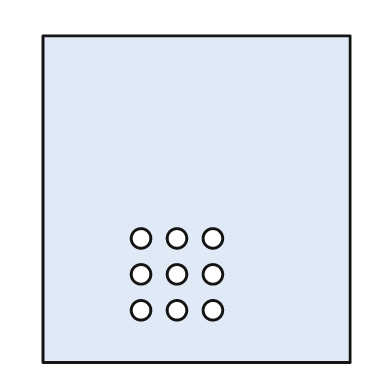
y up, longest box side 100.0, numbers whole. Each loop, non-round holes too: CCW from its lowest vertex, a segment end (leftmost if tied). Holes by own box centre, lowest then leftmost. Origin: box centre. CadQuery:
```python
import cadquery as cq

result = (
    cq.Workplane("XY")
    .moveTo(-47.0, -50.0)
    .lineTo(47.0, -50.0)
    .lineTo(47.0, 50.0)
    .lineTo(-47.0, 50.0)
    .close()
    .moveTo(-17.0, -34.0)
    .circle(3.0)
    .moveTo(-6.0, -34.0)
    .circle(3.0)
    .moveTo(5.0, -34.0)
    .circle(3.0)
    .moveTo(-17.0, -23.0)
    .circle(3.0)
    .moveTo(-6.0, -23.0)
    .circle(3.0)
    .moveTo(5.0, -23.0)
    .circle(3.0)
    .moveTo(-17.0, -12.0)
    .circle(3.0)
    .moveTo(-6.0, -12.0)
    .circle(3.0)
    .moveTo(5.0, -12.0)
    .circle(3.0)
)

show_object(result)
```